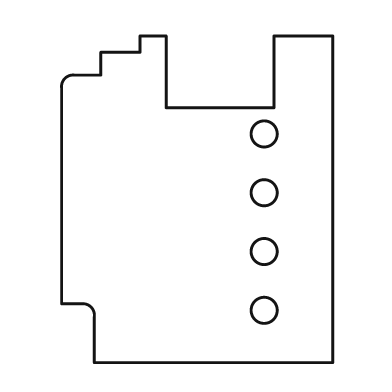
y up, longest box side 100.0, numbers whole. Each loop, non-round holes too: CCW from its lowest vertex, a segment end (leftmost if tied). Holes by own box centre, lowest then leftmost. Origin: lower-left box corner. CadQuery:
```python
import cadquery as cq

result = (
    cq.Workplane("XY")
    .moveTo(10.0, 0.0)
    .lineTo(83.0, 0.0)
    .lineTo(83.0, 100.0)
    .lineTo(65.0, 100.0)
    .lineTo(65.0, 78.0)
    .lineTo(32.0, 78.0)
    .lineTo(32.0, 100.0)
    .lineTo(24.0, 100.0)
    .lineTo(24.0, 95.0)
    .lineTo(12.0, 95.0)
    .lineTo(12.0, 88.0)
    .lineTo(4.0, 88.0)
    .threePointArc((1.0, 87.0), (0.0, 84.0))
    .lineTo(0.0, 18.0)
    .lineTo(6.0, 18.0)
    .threePointArc((9.0, 17.0), (10.0, 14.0))
    .close()
    .moveTo(62.0, 16.0)
    .circle(4.0)
    .moveTo(62.0, 34.0)
    .circle(4.0)
    .moveTo(62.0, 52.0)
    .circle(4.0)
    .moveTo(62.0, 70.0)
    .circle(4.0)
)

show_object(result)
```